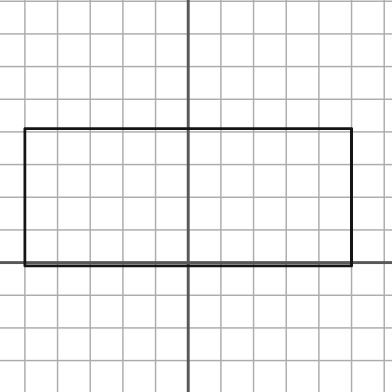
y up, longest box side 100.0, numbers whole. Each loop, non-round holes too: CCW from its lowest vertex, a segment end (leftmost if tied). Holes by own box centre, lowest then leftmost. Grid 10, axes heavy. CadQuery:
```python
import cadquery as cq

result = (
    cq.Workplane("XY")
    .moveTo(-50.0, -1.0)
    .lineTo(50.0, -1.0)
    .lineTo(50.0, 41.0)
    .lineTo(-50.0, 41.0)
    .close()
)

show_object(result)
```